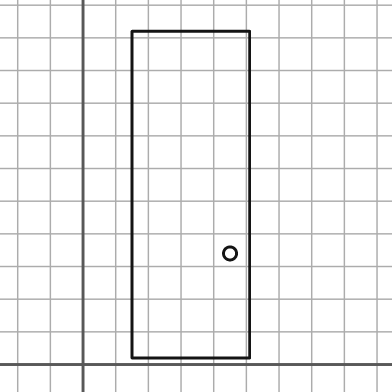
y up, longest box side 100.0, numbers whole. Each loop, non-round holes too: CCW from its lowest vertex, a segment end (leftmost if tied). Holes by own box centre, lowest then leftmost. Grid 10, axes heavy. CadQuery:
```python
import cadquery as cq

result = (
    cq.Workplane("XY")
    .moveTo(15.0, 2.0)
    .lineTo(51.0, 2.0)
    .lineTo(51.0, 102.0)
    .lineTo(15.0, 102.0)
    .close()
    .moveTo(45.0, 34.0)
    .circle(2.0)
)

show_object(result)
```